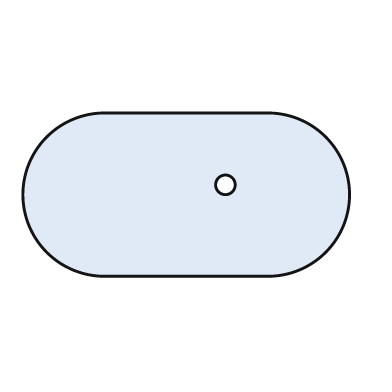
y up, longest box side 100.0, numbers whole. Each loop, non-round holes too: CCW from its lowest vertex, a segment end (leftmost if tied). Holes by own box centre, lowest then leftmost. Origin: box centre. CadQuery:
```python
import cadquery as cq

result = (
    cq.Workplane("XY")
    .moveTo(-25.0, -25.0)
    .lineTo(25.0, -25.0)
    .threePointArc((50.0, 0.0), (25.0, 25.0))
    .lineTo(-25.0, 25.0)
    .threePointArc((-50.0, 0.0), (-25.0, -25.0))
    .close()
    .moveTo(12.0, 3.0)
    .circle(3.0)
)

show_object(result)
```